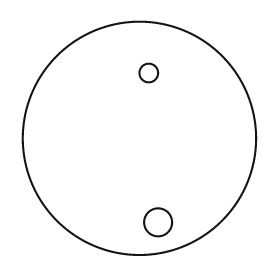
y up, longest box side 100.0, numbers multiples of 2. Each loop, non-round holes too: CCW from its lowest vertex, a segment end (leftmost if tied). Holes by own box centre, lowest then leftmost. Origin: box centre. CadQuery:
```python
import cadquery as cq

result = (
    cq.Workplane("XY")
    .moveTo(0.0, 0.0)
    .circle(50.0)
    .moveTo(8.0, -36.0)
    .circle(6.0)
    .moveTo(4.0, 28.0)
    .circle(4.0)
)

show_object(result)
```